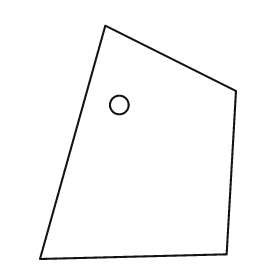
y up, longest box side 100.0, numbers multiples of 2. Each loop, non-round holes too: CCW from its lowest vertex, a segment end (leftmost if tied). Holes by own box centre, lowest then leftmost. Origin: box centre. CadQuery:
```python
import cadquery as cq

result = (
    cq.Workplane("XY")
    .moveTo(-42.0, -50.0)
    .lineTo(38.0, -48.0)
    .lineTo(42.0, 22.0)
    .lineTo(-14.0, 50.0)
    .close()
    .moveTo(-8.0, 16.0)
    .circle(4.0)
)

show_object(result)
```